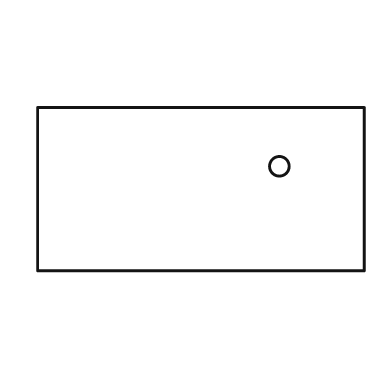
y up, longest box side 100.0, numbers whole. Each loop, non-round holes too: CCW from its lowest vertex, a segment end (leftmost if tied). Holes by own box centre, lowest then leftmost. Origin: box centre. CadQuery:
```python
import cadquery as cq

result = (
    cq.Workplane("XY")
    .moveTo(-50.0, -25.0)
    .lineTo(50.0, -25.0)
    .lineTo(50.0, 25.0)
    .lineTo(-50.0, 25.0)
    .close()
    .moveTo(24.0, 7.0)
    .circle(3.0)
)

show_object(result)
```